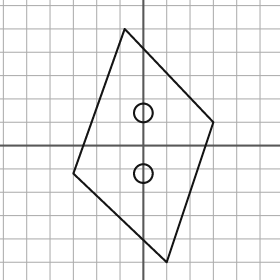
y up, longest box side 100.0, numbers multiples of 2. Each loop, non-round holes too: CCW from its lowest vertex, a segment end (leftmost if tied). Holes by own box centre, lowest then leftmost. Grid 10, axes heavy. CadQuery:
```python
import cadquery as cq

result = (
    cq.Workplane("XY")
    .moveTo(10.0, -50.0)
    .lineTo(30.0, 10.0)
    .lineTo(-8.0, 50.0)
    .lineTo(-30.0, -12.0)
    .close()
    .moveTo(0.0, -12.0)
    .circle(4.0)
    .moveTo(0.0, 14.0)
    .circle(4.0)
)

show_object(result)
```